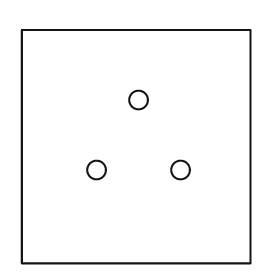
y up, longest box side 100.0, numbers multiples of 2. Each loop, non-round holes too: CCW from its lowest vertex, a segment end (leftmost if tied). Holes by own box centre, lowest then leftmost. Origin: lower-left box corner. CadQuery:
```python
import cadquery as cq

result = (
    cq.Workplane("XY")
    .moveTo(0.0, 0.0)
    .lineTo(98.0, 0.0)
    .lineTo(98.0, 100.0)
    .lineTo(0.0, 100.0)
    .close()
    .moveTo(32.0, 40.0)
    .circle(4.0)
    .moveTo(68.0, 40.0)
    .circle(4.0)
    .moveTo(50.0, 70.0)
    .circle(4.0)
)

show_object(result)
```